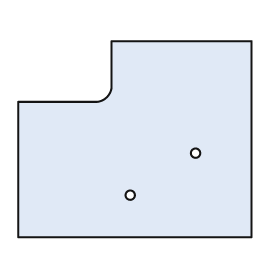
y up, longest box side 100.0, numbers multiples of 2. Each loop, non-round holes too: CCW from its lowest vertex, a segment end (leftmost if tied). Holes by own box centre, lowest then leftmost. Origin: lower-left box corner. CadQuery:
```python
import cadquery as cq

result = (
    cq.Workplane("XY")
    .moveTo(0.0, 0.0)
    .lineTo(100.0, 0.0)
    .lineTo(100.0, 84.0)
    .lineTo(40.0, 84.0)
    .lineTo(40.0, 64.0)
    .threePointArc((38.0, 60.0), (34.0, 58.0))
    .lineTo(0.0, 58.0)
    .close()
    .moveTo(48.0, 18.0)
    .circle(2.0)
    .moveTo(76.0, 36.0)
    .circle(2.0)
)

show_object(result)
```